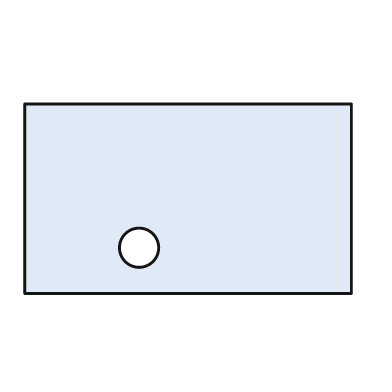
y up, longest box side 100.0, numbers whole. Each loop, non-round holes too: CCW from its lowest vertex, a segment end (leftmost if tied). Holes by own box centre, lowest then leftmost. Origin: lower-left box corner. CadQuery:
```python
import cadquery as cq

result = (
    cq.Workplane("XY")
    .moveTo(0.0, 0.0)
    .lineTo(100.0, 0.0)
    .lineTo(100.0, 58.0)
    .lineTo(0.0, 58.0)
    .close()
    .moveTo(35.0, 14.0)
    .circle(6.0)
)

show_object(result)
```